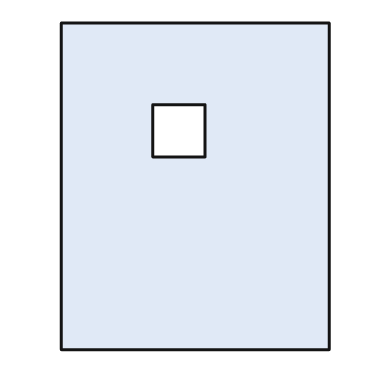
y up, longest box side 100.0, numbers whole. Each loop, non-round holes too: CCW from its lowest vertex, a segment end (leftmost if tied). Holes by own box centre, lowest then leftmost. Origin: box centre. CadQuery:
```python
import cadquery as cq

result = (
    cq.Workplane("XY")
    .moveTo(-41.0, -50.0)
    .lineTo(41.0, -50.0)
    .lineTo(41.0, 50.0)
    .lineTo(-41.0, 50.0)
    .close()
    .moveTo(-13.0, 9.0)
    .lineTo(3.0, 9.0)
    .lineTo(3.0, 25.0)
    .lineTo(-13.0, 25.0)
    .close()
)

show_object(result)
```